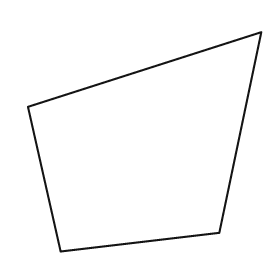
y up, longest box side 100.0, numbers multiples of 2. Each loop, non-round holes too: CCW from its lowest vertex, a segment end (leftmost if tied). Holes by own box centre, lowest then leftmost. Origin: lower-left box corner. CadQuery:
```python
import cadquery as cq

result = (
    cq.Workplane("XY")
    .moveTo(14.0, 0.0)
    .lineTo(82.0, 8.0)
    .lineTo(100.0, 94.0)
    .lineTo(0.0, 62.0)
    .close()
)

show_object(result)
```